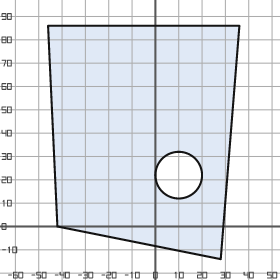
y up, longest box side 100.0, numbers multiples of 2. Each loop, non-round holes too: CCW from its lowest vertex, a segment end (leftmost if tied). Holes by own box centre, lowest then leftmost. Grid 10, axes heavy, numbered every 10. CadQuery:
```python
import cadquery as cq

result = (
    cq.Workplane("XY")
    .moveTo(28.0, -14.0)
    .lineTo(36.0, 86.0)
    .lineTo(-46.0, 86.0)
    .lineTo(-42.0, 0.0)
    .close()
    .moveTo(10.0, 22.0)
    .circle(10.0)
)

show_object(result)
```